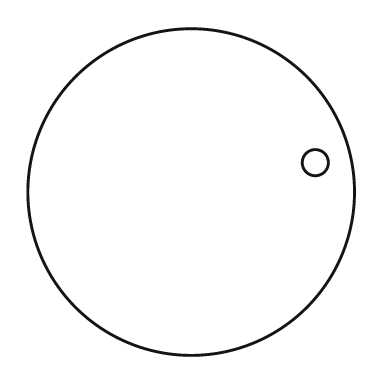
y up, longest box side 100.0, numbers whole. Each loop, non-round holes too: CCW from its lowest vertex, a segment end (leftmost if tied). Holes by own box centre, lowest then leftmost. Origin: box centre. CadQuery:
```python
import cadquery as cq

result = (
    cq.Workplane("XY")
    .moveTo(0.0, 0.0)
    .circle(50.0)
    .moveTo(38.0, 9.0)
    .circle(4.0)
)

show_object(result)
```